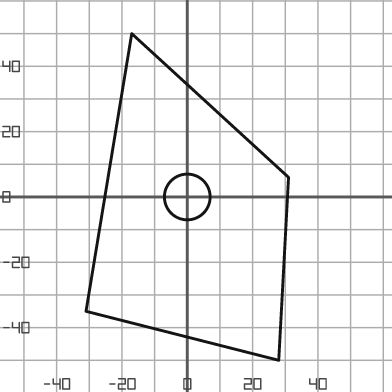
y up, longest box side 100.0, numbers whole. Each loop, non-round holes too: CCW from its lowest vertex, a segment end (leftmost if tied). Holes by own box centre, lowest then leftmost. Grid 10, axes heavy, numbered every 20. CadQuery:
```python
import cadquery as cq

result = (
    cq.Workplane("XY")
    .moveTo(28.0, -50.0)
    .lineTo(31.0, 6.0)
    .lineTo(-17.0, 50.0)
    .lineTo(-31.0, -35.0)
    .close()
    .moveTo(0.0, 0.0)
    .circle(7.0)
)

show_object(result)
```